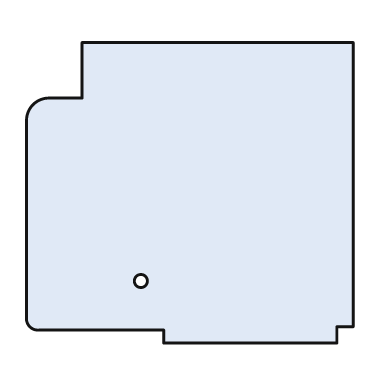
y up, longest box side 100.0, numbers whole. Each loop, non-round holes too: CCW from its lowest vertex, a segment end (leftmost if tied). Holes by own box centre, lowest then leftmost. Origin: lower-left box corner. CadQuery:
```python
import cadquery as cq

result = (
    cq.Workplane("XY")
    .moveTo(42.0, 0.0)
    .lineTo(95.0, 0.0)
    .lineTo(95.0, 5.0)
    .lineTo(100.0, 5.0)
    .lineTo(100.0, 92.0)
    .lineTo(17.0, 92.0)
    .lineTo(17.0, 75.0)
    .lineTo(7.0, 75.0)
    .threePointArc((2.0, 73.0), (0.0, 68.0))
    .lineTo(0.0, 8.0)
    .threePointArc((1.0, 5.0), (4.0, 4.0))
    .lineTo(42.0, 4.0)
    .close()
    .moveTo(35.0, 19.0)
    .circle(2.0)
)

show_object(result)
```